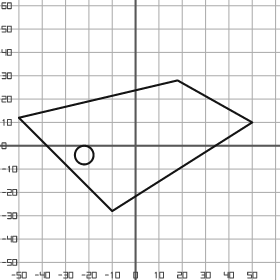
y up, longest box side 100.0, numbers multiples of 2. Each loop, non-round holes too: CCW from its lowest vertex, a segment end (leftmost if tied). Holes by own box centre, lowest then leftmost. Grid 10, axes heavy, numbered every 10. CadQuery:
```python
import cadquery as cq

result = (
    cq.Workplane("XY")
    .moveTo(-10.0, -28.0)
    .lineTo(50.0, 10.0)
    .lineTo(18.0, 28.0)
    .lineTo(-50.0, 12.0)
    .close()
    .moveTo(-22.0, -4.0)
    .circle(4.0)
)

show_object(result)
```